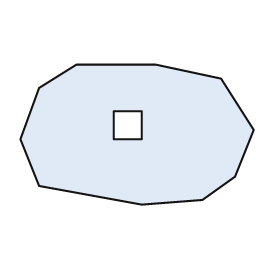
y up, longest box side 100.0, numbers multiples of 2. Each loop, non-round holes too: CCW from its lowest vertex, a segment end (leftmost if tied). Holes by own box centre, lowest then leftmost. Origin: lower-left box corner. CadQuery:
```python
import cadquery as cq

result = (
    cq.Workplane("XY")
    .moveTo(52.0, 0.0)
    .lineTo(78.0, 2.0)
    .lineTo(92.0, 12.0)
    .lineTo(100.0, 32.0)
    .lineTo(86.0, 54.0)
    .lineTo(58.0, 60.0)
    .lineTo(24.0, 60.0)
    .lineTo(8.0, 50.0)
    .lineTo(0.0, 28.0)
    .lineTo(8.0, 8.0)
    .close()
    .moveTo(40.0, 28.0)
    .lineTo(52.0, 28.0)
    .lineTo(52.0, 40.0)
    .lineTo(40.0, 40.0)
    .close()
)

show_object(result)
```